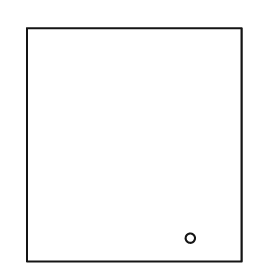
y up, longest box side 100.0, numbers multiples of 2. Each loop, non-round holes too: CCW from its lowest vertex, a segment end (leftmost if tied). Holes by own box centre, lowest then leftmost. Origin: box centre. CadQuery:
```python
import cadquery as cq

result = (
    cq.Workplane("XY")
    .moveTo(-46.0, -50.0)
    .lineTo(46.0, -50.0)
    .lineTo(46.0, 50.0)
    .lineTo(-46.0, 50.0)
    .close()
    .moveTo(24.0, -40.0)
    .circle(2.0)
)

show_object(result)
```